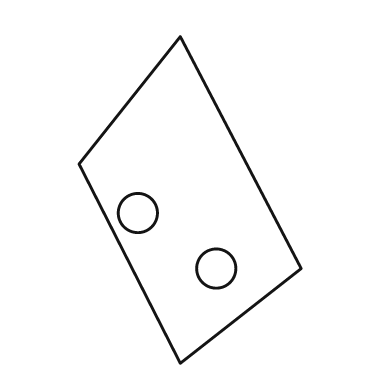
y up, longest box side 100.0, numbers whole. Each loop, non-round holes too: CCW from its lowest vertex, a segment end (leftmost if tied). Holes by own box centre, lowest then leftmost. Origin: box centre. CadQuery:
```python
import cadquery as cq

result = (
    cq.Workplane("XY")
    .moveTo(-3.0, -50.0)
    .lineTo(34.0, -21.0)
    .lineTo(-3.0, 50.0)
    .lineTo(-34.0, 11.0)
    .close()
    .moveTo(8.0, -21.0)
    .circle(6.0)
    .moveTo(-16.0, -4.0)
    .circle(6.0)
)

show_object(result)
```